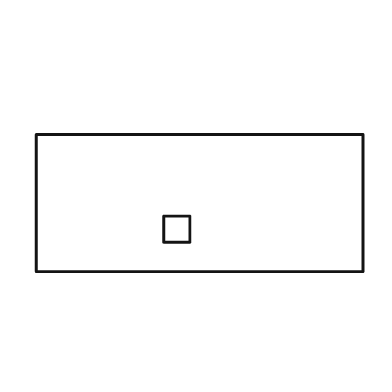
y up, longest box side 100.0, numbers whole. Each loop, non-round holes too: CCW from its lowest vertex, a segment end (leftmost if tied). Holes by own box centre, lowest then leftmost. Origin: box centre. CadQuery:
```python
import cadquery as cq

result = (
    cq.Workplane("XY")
    .moveTo(-50.0, -21.0)
    .lineTo(50.0, -21.0)
    .lineTo(50.0, 21.0)
    .lineTo(-50.0, 21.0)
    .close()
    .moveTo(-11.0, -12.0)
    .lineTo(-3.0, -12.0)
    .lineTo(-3.0, -4.0)
    .lineTo(-11.0, -4.0)
    .close()
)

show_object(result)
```